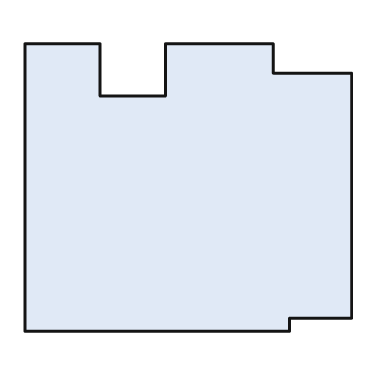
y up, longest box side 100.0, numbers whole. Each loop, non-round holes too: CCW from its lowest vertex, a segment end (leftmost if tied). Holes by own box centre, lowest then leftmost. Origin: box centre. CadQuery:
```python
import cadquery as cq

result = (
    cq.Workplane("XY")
    .moveTo(-50.0, -44.0)
    .lineTo(31.0, -44.0)
    .lineTo(31.0, -40.0)
    .lineTo(50.0, -40.0)
    .lineTo(50.0, 35.0)
    .lineTo(26.0, 35.0)
    .lineTo(26.0, 44.0)
    .lineTo(-7.0, 44.0)
    .lineTo(-7.0, 28.0)
    .lineTo(-27.0, 28.0)
    .lineTo(-27.0, 44.0)
    .lineTo(-50.0, 44.0)
    .close()
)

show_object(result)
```